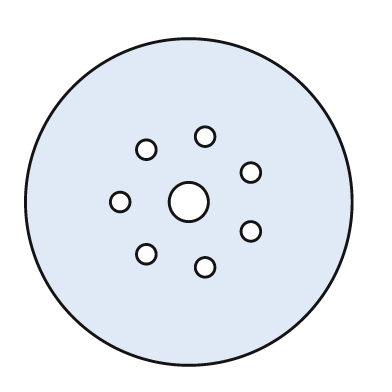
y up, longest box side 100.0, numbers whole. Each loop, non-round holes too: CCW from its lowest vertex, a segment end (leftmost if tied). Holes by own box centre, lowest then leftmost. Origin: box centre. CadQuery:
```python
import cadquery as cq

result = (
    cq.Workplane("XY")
    .moveTo(0.0, 0.0)
    .circle(50.0)
    .moveTo(5.0, -20.0)
    .circle(3.0)
    .moveTo(-13.0, -16.0)
    .circle(3.0)
    .moveTo(19.0, -9.0)
    .circle(3.0)
    .moveTo(-21.0, 0.0)
    .circle(3.0)
    .moveTo(0.0, 0.0)
    .circle(6.0)
    .moveTo(19.0, 9.0)
    .circle(3.0)
    .moveTo(-13.0, 16.0)
    .circle(3.0)
    .moveTo(5.0, 20.0)
    .circle(3.0)
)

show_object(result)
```